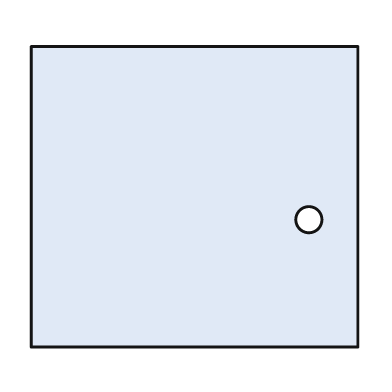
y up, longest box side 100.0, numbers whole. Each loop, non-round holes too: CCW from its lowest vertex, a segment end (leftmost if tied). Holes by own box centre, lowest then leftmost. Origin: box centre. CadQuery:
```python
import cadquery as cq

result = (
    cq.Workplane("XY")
    .moveTo(-50.0, -46.0)
    .lineTo(50.0, -46.0)
    .lineTo(50.0, 46.0)
    .lineTo(-50.0, 46.0)
    .close()
    .moveTo(35.0, -7.0)
    .circle(4.0)
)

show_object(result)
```